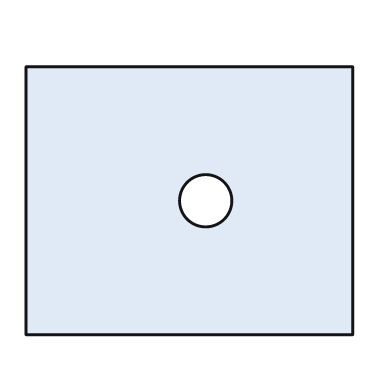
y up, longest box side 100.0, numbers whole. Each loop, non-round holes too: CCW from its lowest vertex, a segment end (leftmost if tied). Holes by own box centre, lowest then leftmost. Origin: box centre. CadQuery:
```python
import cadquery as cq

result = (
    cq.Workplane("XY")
    .moveTo(-50.0, -41.0)
    .lineTo(50.0, -41.0)
    .lineTo(50.0, 41.0)
    .lineTo(-50.0, 41.0)
    .close()
    .moveTo(5.0, 0.0)
    .circle(8.0)
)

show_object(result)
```